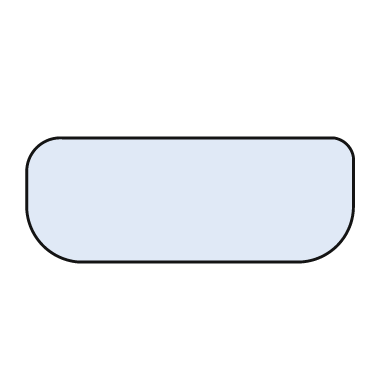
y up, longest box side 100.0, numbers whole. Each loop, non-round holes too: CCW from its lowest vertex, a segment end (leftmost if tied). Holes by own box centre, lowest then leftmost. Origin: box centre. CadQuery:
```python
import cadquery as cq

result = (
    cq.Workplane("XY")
    .moveTo(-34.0, -19.0)
    .lineTo(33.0, -19.0)
    .threePointArc((45.0, -14.0), (50.0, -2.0))
    .lineTo(50.0, 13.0)
    .threePointArc((48.0, 17.0), (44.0, 19.0))
    .lineTo(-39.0, 19.0)
    .threePointArc((-47.0, 16.0), (-50.0, 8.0))
    .lineTo(-50.0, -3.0)
    .threePointArc((-45.0, -14.0), (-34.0, -19.0))
    .close()
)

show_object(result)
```